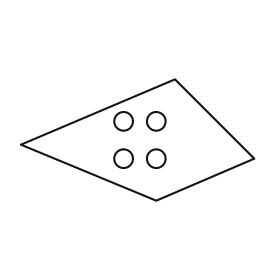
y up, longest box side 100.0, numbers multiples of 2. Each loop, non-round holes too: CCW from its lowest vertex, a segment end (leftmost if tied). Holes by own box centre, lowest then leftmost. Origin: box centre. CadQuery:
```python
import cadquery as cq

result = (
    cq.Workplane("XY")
    .moveTo(8.0, -26.0)
    .lineTo(50.0, -8.0)
    .lineTo(16.0, 26.0)
    .lineTo(-50.0, -2.0)
    .close()
    .moveTo(-6.0, -8.0)
    .circle(4.0)
    .moveTo(8.0, -8.0)
    .circle(4.0)
    .moveTo(-6.0, 8.0)
    .circle(4.0)
    .moveTo(8.0, 8.0)
    .circle(4.0)
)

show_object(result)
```